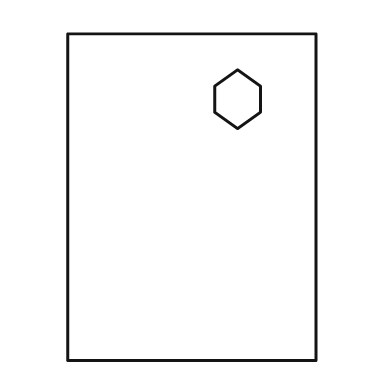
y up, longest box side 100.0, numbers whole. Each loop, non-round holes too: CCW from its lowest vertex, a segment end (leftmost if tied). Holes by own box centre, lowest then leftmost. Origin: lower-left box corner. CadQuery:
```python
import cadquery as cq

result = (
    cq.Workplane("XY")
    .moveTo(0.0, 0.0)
    .lineTo(76.0, 0.0)
    .lineTo(76.0, 100.0)
    .lineTo(0.0, 100.0)
    .close()
    .moveTo(52.0, 71.0)
    .lineTo(59.0, 76.0)
    .lineTo(59.0, 84.0)
    .lineTo(52.0, 89.0)
    .lineTo(45.0, 84.0)
    .lineTo(45.0, 76.0)
    .close()
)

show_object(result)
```